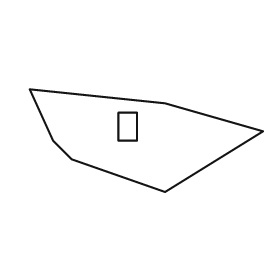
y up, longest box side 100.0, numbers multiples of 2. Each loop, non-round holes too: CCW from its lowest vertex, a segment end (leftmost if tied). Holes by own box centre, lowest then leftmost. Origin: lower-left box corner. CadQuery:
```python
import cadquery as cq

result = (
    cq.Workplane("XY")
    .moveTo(58.0, 0.0)
    .lineTo(100.0, 26.0)
    .lineTo(58.0, 38.0)
    .lineTo(0.0, 44.0)
    .lineTo(10.0, 22.0)
    .lineTo(18.0, 14.0)
    .close()
    .moveTo(38.0, 22.0)
    .lineTo(46.0, 22.0)
    .lineTo(46.0, 34.0)
    .lineTo(38.0, 34.0)
    .close()
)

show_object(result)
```